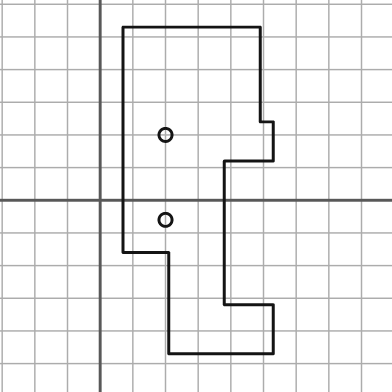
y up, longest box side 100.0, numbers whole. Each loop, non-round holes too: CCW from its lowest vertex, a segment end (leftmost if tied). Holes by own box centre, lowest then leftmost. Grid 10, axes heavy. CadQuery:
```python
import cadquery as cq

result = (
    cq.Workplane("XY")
    .moveTo(21.0, -47.0)
    .lineTo(53.0, -47.0)
    .lineTo(53.0, -32.0)
    .lineTo(38.0, -32.0)
    .lineTo(38.0, 12.0)
    .lineTo(53.0, 12.0)
    .lineTo(53.0, 24.0)
    .lineTo(49.0, 24.0)
    .lineTo(49.0, 53.0)
    .lineTo(7.0, 53.0)
    .lineTo(7.0, -16.0)
    .lineTo(21.0, -16.0)
    .close()
    .moveTo(20.0, -6.0)
    .circle(2.0)
    .moveTo(20.0, 20.0)
    .circle(2.0)
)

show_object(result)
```